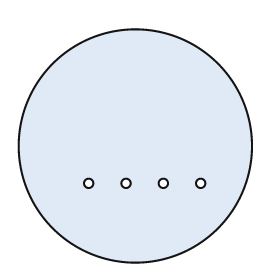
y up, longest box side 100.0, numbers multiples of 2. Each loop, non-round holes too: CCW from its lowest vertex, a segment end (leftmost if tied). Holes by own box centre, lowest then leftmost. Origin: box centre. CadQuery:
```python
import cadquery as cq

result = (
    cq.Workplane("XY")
    .moveTo(0.0, 0.0)
    .circle(50.0)
    .moveTo(-20.0, -16.0)
    .circle(2.0)
    .moveTo(-4.0, -16.0)
    .circle(2.0)
    .moveTo(12.0, -16.0)
    .circle(2.0)
    .moveTo(28.0, -16.0)
    .circle(2.0)
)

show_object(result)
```